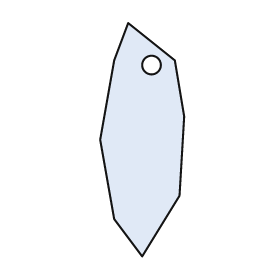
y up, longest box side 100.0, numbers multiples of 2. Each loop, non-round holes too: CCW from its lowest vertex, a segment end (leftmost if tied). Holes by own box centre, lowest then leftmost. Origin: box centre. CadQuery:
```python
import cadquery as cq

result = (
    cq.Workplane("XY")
    .moveTo(0.0, -50.0)
    .lineTo(16.0, -24.0)
    .lineTo(18.0, 10.0)
    .lineTo(14.0, 34.0)
    .lineTo(-6.0, 50.0)
    .lineTo(-12.0, 34.0)
    .lineTo(-18.0, 0.0)
    .lineTo(-12.0, -34.0)
    .close()
    .moveTo(4.0, 32.0)
    .circle(4.0)
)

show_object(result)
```